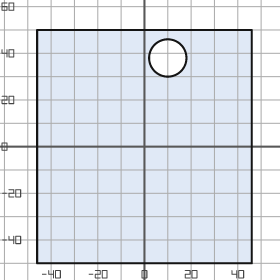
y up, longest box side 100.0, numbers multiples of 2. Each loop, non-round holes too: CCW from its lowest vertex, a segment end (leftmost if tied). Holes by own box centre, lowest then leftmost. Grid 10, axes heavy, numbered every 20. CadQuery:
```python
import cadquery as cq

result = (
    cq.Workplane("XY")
    .moveTo(-46.0, -50.0)
    .lineTo(46.0, -50.0)
    .lineTo(46.0, 50.0)
    .lineTo(-46.0, 50.0)
    .close()
    .moveTo(10.0, 38.0)
    .circle(8.0)
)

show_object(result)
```